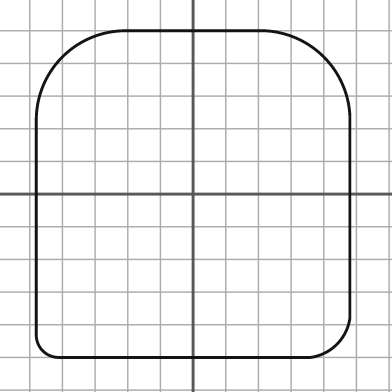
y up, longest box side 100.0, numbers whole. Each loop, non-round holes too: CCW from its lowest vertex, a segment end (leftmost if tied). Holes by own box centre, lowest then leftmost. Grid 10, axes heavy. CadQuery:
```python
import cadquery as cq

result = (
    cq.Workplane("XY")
    .moveTo(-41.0, -50.0)
    .lineTo(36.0, -50.0)
    .threePointArc((44.0, -46.0), (48.0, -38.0))
    .lineTo(48.0, 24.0)
    .threePointArc((40.0, 42.0), (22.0, 50.0))
    .lineTo(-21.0, 50.0)
    .threePointArc((-40.0, 42.0), (-48.0, 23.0))
    .lineTo(-48.0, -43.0)
    .threePointArc((-46.0, -48.0), (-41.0, -50.0))
    .close()
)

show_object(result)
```